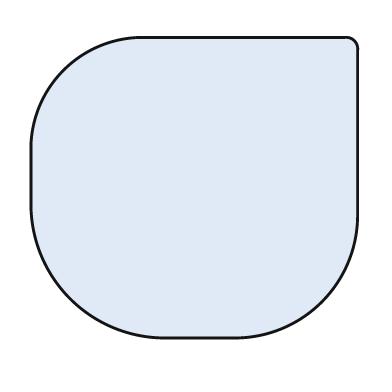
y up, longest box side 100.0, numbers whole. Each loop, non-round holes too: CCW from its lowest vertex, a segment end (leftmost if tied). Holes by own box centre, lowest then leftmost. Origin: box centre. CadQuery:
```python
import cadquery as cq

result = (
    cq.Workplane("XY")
    .moveTo(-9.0, -46.0)
    .lineTo(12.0, -46.0)
    .threePointArc((39.0, -35.0), (50.0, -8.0))
    .lineTo(50.0, 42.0)
    .threePointArc((49.0, 45.0), (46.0, 46.0))
    .lineTo(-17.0, 46.0)
    .threePointArc((-40.0, 36.0), (-50.0, 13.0))
    .lineTo(-50.0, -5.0)
    .threePointArc((-38.0, -34.0), (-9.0, -46.0))
    .close()
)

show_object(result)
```